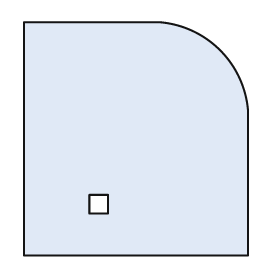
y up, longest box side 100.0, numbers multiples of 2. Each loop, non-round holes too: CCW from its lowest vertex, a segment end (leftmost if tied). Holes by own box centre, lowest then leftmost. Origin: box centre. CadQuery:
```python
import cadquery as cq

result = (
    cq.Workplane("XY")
    .moveTo(-48.0, -50.0)
    .lineTo(48.0, -50.0)
    .lineTo(48.0, 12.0)
    .threePointArc((36.0, 38.0), (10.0, 50.0))
    .lineTo(-48.0, 50.0)
    .close()
    .moveTo(-20.0, -32.0)
    .lineTo(-12.0, -32.0)
    .lineTo(-12.0, -24.0)
    .lineTo(-20.0, -24.0)
    .close()
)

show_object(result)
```